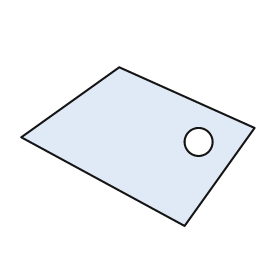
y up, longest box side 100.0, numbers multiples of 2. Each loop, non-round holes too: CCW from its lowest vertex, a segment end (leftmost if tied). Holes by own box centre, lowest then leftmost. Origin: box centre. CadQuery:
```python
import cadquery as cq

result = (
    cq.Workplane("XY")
    .moveTo(20.0, -34.0)
    .lineTo(50.0, 8.0)
    .lineTo(-8.0, 34.0)
    .lineTo(-50.0, 4.0)
    .close()
    .moveTo(26.0, 2.0)
    .circle(6.0)
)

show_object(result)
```